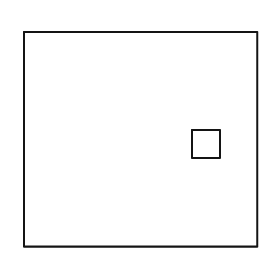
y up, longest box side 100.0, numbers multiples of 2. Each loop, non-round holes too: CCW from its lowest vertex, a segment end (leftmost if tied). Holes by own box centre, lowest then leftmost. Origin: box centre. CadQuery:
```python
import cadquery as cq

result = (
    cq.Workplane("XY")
    .moveTo(-50.0, -46.0)
    .lineTo(50.0, -46.0)
    .lineTo(50.0, 46.0)
    .lineTo(-50.0, 46.0)
    .close()
    .moveTo(22.0, -8.0)
    .lineTo(34.0, -8.0)
    .lineTo(34.0, 4.0)
    .lineTo(22.0, 4.0)
    .close()
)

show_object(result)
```